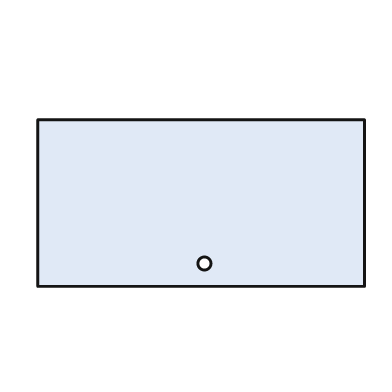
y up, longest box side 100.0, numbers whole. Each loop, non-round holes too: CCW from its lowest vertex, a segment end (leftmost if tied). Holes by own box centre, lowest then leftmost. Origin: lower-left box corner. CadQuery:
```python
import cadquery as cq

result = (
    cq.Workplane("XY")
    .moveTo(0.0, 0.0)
    .lineTo(100.0, 0.0)
    .lineTo(100.0, 51.0)
    .lineTo(0.0, 51.0)
    .close()
    .moveTo(51.0, 7.0)
    .circle(2.0)
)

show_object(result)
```